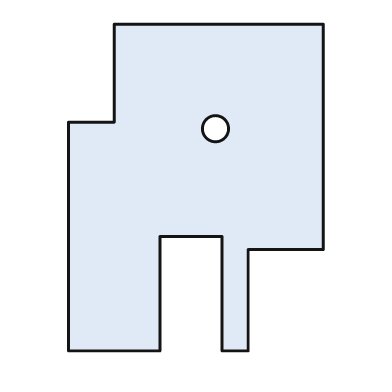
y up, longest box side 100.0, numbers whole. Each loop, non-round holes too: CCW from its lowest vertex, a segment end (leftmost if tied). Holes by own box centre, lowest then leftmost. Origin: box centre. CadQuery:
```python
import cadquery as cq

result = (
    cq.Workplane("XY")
    .moveTo(-39.0, -50.0)
    .lineTo(-11.0, -50.0)
    .lineTo(-11.0, -15.0)
    .lineTo(8.0, -15.0)
    .lineTo(8.0, -50.0)
    .lineTo(16.0, -50.0)
    .lineTo(16.0, -19.0)
    .lineTo(39.0, -19.0)
    .lineTo(39.0, 50.0)
    .lineTo(-25.0, 50.0)
    .lineTo(-25.0, 20.0)
    .lineTo(-39.0, 20.0)
    .close()
    .moveTo(6.0, 18.0)
    .circle(4.0)
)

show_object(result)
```